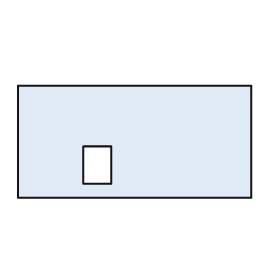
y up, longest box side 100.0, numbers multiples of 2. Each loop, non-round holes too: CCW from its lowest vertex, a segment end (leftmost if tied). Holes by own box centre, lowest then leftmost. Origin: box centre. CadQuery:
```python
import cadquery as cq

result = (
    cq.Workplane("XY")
    .moveTo(-50.0, -24.0)
    .lineTo(50.0, -24.0)
    .lineTo(50.0, 24.0)
    .lineTo(-50.0, 24.0)
    .close()
    .moveTo(-22.0, -18.0)
    .lineTo(-10.0, -18.0)
    .lineTo(-10.0, -2.0)
    .lineTo(-22.0, -2.0)
    .close()
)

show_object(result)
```